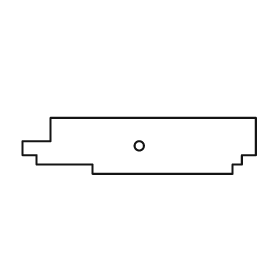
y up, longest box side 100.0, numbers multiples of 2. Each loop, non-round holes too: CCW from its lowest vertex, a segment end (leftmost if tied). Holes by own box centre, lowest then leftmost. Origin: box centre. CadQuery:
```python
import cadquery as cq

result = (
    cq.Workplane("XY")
    .moveTo(-20.0, -12.0)
    .lineTo(40.0, -12.0)
    .lineTo(40.0, -8.0)
    .lineTo(44.0, -8.0)
    .lineTo(44.0, -4.0)
    .lineTo(50.0, -4.0)
    .lineTo(50.0, 12.0)
    .lineTo(-38.0, 12.0)
    .lineTo(-38.0, 2.0)
    .lineTo(-50.0, 2.0)
    .lineTo(-50.0, -4.0)
    .lineTo(-44.0, -4.0)
    .lineTo(-44.0, -8.0)
    .lineTo(-20.0, -8.0)
    .close()
    .moveTo(0.0, 0.0)
    .circle(2.0)
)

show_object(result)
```